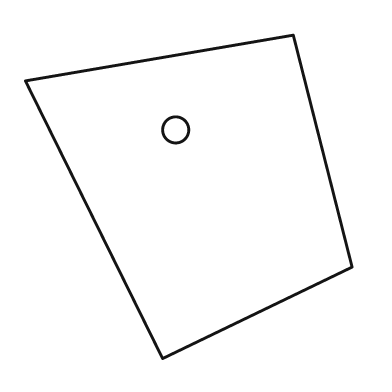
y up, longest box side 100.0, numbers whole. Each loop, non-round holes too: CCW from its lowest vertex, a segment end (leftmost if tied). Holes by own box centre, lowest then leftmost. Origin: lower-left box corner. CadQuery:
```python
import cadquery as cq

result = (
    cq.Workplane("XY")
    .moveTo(42.0, 0.0)
    .lineTo(100.0, 28.0)
    .lineTo(82.0, 99.0)
    .lineTo(0.0, 85.0)
    .close()
    .moveTo(46.0, 70.0)
    .circle(4.0)
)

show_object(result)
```